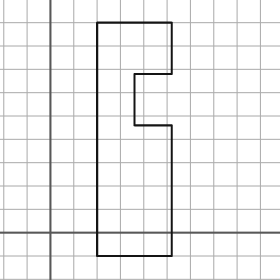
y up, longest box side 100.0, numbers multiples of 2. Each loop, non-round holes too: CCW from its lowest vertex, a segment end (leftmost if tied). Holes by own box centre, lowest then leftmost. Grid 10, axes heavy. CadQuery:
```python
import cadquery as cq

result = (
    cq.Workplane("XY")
    .moveTo(20.0, -10.0)
    .lineTo(52.0, -10.0)
    .lineTo(52.0, 46.0)
    .lineTo(36.0, 46.0)
    .lineTo(36.0, 68.0)
    .lineTo(52.0, 68.0)
    .lineTo(52.0, 90.0)
    .lineTo(20.0, 90.0)
    .close()
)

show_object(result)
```